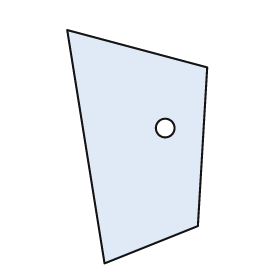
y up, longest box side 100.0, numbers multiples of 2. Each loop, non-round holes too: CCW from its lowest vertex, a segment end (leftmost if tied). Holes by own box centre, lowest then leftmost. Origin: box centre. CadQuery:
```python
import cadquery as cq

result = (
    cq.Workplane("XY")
    .moveTo(-14.0, -50.0)
    .lineTo(26.0, -34.0)
    .lineTo(30.0, 34.0)
    .lineTo(-30.0, 50.0)
    .close()
    .moveTo(12.0, 8.0)
    .circle(4.0)
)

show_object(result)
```